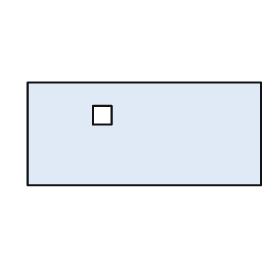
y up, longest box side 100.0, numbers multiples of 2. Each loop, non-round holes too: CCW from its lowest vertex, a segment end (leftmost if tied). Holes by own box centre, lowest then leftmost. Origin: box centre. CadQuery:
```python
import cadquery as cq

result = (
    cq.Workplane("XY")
    .moveTo(-50.0, -22.0)
    .lineTo(50.0, -22.0)
    .lineTo(50.0, 22.0)
    .lineTo(-50.0, 22.0)
    .close()
    .moveTo(-22.0, 4.0)
    .lineTo(-14.0, 4.0)
    .lineTo(-14.0, 12.0)
    .lineTo(-22.0, 12.0)
    .close()
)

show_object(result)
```